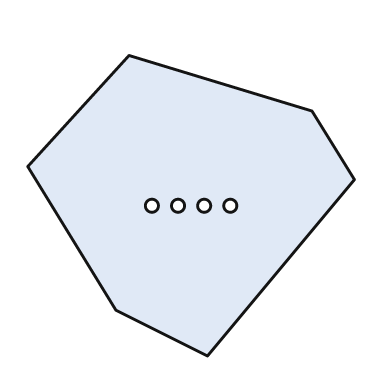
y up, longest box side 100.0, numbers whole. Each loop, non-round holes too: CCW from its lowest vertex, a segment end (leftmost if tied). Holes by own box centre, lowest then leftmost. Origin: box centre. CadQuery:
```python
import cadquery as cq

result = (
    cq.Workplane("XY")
    .moveTo(5.0, -46.0)
    .lineTo(50.0, 8.0)
    .lineTo(37.0, 29.0)
    .lineTo(-19.0, 46.0)
    .lineTo(-50.0, 12.0)
    .lineTo(-23.0, -32.0)
    .close()
    .moveTo(-12.0, 0.0)
    .circle(2.0)
    .moveTo(-4.0, 0.0)
    .circle(2.0)
    .moveTo(4.0, 0.0)
    .circle(2.0)
    .moveTo(12.0, 0.0)
    .circle(2.0)
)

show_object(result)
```